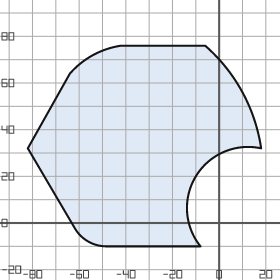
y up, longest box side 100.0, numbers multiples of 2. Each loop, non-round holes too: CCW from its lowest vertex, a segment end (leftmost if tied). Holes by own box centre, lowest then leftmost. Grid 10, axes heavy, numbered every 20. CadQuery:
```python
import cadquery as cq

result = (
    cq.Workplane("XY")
    .moveTo(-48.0, -10.0)
    .lineTo(-8.0, -10.0)
    .threePointArc((-10.0, 20.0), (18.0, 32.0))
    .threePointArc((10.0, 56.0), (-6.0, 76.0))
    .lineTo(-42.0, 76.0)
    .threePointArc((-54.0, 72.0), (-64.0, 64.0))
    .lineTo(-82.0, 32.0)
    .lineTo(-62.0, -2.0)
    .threePointArc((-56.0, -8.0), (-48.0, -10.0))
    .close()
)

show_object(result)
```